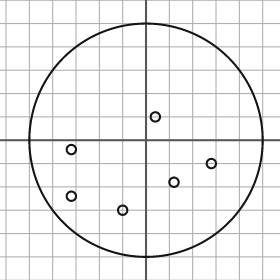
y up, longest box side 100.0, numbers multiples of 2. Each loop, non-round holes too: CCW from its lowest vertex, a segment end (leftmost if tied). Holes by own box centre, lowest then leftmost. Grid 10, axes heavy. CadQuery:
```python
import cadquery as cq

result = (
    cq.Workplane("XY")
    .moveTo(0.0, 0.0)
    .circle(50.0)
    .moveTo(-10.0, -30.0)
    .circle(2.0)
    .moveTo(-32.0, -24.0)
    .circle(2.0)
    .moveTo(12.0, -18.0)
    .circle(2.0)
    .moveTo(28.0, -10.0)
    .circle(2.0)
    .moveTo(-32.0, -4.0)
    .circle(2.0)
    .moveTo(4.0, 10.0)
    .circle(2.0)
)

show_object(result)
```